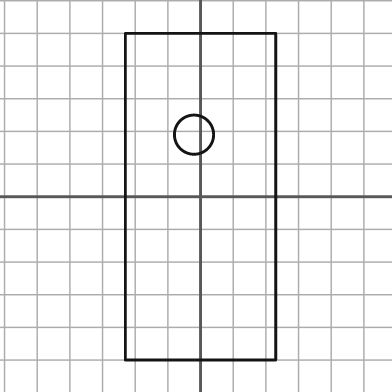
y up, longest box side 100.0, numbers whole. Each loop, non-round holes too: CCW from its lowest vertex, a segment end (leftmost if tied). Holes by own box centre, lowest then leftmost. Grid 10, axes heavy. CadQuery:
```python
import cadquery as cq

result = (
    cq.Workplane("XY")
    .moveTo(-23.0, -50.0)
    .lineTo(23.0, -50.0)
    .lineTo(23.0, 50.0)
    .lineTo(-23.0, 50.0)
    .close()
    .moveTo(-2.0, 19.0)
    .circle(6.0)
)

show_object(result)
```